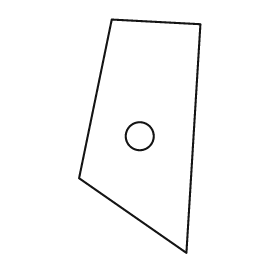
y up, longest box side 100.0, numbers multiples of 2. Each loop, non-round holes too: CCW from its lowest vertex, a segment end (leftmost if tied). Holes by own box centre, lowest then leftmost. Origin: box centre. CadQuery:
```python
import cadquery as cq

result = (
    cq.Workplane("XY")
    .moveTo(20.0, -50.0)
    .lineTo(26.0, 48.0)
    .lineTo(-12.0, 50.0)
    .lineTo(-26.0, -18.0)
    .close()
    .moveTo(0.0, 0.0)
    .circle(6.0)
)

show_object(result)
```